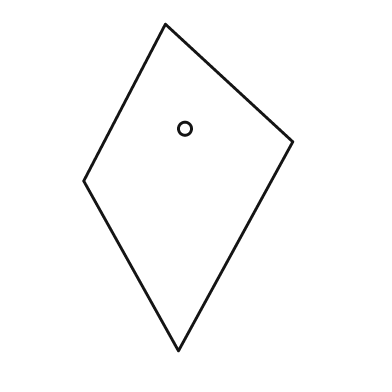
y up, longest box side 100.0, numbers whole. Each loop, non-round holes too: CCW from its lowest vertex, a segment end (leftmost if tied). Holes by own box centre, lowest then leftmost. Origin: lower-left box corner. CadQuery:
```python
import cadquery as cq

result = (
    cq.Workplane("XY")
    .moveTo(29.0, 0.0)
    .lineTo(64.0, 64.0)
    .lineTo(25.0, 100.0)
    .lineTo(0.0, 52.0)
    .close()
    .moveTo(31.0, 68.0)
    .circle(2.0)
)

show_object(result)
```